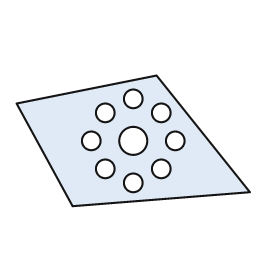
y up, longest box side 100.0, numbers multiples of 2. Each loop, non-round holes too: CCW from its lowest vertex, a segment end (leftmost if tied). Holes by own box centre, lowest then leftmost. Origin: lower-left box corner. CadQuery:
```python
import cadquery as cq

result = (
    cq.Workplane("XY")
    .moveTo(24.0, 0.0)
    .lineTo(100.0, 6.0)
    .lineTo(60.0, 56.0)
    .lineTo(0.0, 44.0)
    .close()
    .moveTo(50.0, 10.0)
    .circle(4.0)
    .moveTo(38.0, 16.0)
    .circle(4.0)
    .moveTo(62.0, 16.0)
    .circle(4.0)
    .moveTo(32.0, 28.0)
    .circle(4.0)
    .moveTo(50.0, 28.0)
    .circle(6.0)
    .moveTo(68.0, 28.0)
    .circle(4.0)
    .moveTo(38.0, 40.0)
    .circle(4.0)
    .moveTo(62.0, 40.0)
    .circle(4.0)
    .moveTo(50.0, 46.0)
    .circle(4.0)
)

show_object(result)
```